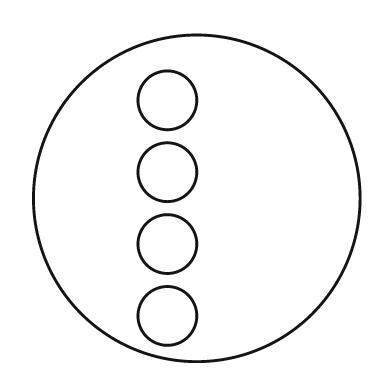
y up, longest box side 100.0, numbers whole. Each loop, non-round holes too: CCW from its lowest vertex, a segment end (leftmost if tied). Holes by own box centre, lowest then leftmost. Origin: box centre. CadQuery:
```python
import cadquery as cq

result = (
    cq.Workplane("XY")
    .moveTo(0.0, 0.0)
    .circle(50.0)
    .moveTo(-9.0, -36.0)
    .circle(9.0)
    .moveTo(-9.0, -14.0)
    .circle(9.0)
    .moveTo(-9.0, 8.0)
    .circle(9.0)
    .moveTo(-9.0, 30.0)
    .circle(9.0)
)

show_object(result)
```